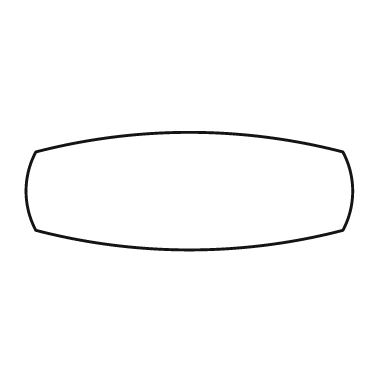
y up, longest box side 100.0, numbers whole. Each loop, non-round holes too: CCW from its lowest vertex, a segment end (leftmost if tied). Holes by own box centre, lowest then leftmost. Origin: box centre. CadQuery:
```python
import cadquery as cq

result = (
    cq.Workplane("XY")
    .moveTo(-47.0, -12.0)
    .threePointArc((0.0, -18.0), (47.0, -12.0))
    .threePointArc((50.0, 0.0), (47.0, 12.0))
    .threePointArc((0.0, 18.0), (-47.0, 12.0))
    .threePointArc((-50.0, 0.0), (-47.0, -12.0))
    .close()
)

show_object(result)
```